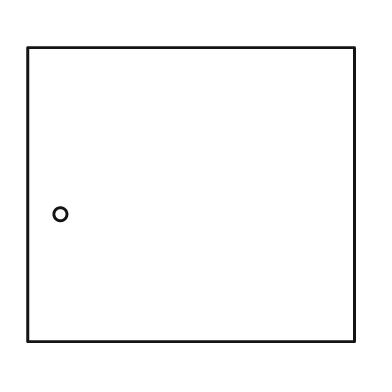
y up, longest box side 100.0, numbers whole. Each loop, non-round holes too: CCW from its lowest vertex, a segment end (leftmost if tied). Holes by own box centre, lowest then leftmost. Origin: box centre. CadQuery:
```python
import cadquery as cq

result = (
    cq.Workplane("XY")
    .moveTo(-50.0, -45.0)
    .lineTo(50.0, -45.0)
    .lineTo(50.0, 45.0)
    .lineTo(-50.0, 45.0)
    .close()
    .moveTo(-40.0, -6.0)
    .circle(2.0)
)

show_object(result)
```